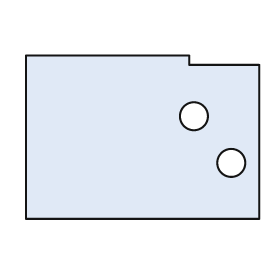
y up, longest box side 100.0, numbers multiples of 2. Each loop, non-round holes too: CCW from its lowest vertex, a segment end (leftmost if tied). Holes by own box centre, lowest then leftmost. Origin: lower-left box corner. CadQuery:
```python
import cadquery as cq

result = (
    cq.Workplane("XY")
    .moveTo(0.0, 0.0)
    .lineTo(100.0, 0.0)
    .lineTo(100.0, 66.0)
    .lineTo(70.0, 66.0)
    .lineTo(70.0, 70.0)
    .lineTo(0.0, 70.0)
    .close()
    .moveTo(88.0, 24.0)
    .circle(6.0)
    .moveTo(72.0, 44.0)
    .circle(6.0)
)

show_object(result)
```